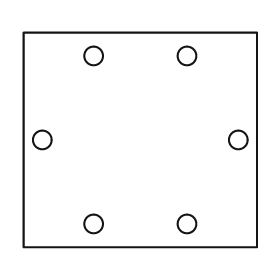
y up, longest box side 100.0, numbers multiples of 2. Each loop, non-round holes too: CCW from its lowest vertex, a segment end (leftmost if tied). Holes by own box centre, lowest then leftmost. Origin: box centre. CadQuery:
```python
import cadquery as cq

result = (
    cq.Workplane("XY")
    .moveTo(-50.0, -46.0)
    .lineTo(50.0, -46.0)
    .lineTo(50.0, 46.0)
    .lineTo(-50.0, 46.0)
    .close()
    .moveTo(-20.0, -36.0)
    .circle(4.0)
    .moveTo(20.0, -36.0)
    .circle(4.0)
    .moveTo(-42.0, 0.0)
    .circle(4.0)
    .moveTo(42.0, 0.0)
    .circle(4.0)
    .moveTo(-20.0, 36.0)
    .circle(4.0)
    .moveTo(20.0, 36.0)
    .circle(4.0)
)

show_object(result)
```